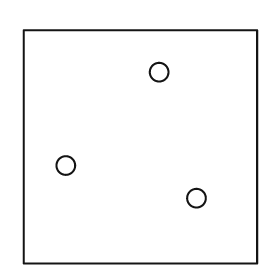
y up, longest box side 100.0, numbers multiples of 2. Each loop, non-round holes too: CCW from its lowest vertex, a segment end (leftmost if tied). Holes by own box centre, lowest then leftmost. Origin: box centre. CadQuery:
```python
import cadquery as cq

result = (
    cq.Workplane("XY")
    .moveTo(-50.0, -50.0)
    .lineTo(50.0, -50.0)
    .lineTo(50.0, 50.0)
    .lineTo(-50.0, 50.0)
    .close()
    .moveTo(24.0, -22.0)
    .circle(4.0)
    .moveTo(-32.0, -8.0)
    .circle(4.0)
    .moveTo(8.0, 32.0)
    .circle(4.0)
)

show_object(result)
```